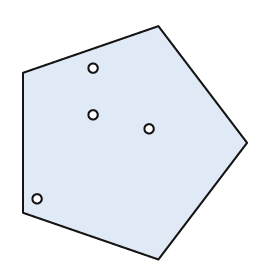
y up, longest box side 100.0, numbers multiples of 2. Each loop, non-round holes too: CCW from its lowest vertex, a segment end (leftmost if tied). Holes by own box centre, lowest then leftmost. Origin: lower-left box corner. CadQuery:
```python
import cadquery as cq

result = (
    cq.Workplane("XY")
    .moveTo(58.0, 0.0)
    .lineTo(96.0, 50.0)
    .lineTo(58.0, 100.0)
    .lineTo(0.0, 80.0)
    .lineTo(0.0, 20.0)
    .close()
    .moveTo(6.0, 26.0)
    .circle(2.0)
    .moveTo(54.0, 56.0)
    .circle(2.0)
    .moveTo(30.0, 62.0)
    .circle(2.0)
    .moveTo(30.0, 82.0)
    .circle(2.0)
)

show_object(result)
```